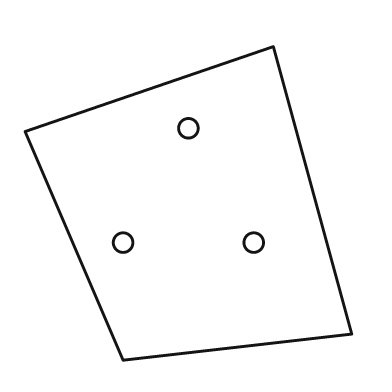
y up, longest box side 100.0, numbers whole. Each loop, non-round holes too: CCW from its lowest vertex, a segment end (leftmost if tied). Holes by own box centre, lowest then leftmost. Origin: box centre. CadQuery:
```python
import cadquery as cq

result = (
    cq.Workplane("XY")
    .moveTo(-20.0, -48.0)
    .lineTo(50.0, -40.0)
    .lineTo(26.0, 48.0)
    .lineTo(-50.0, 22.0)
    .close()
    .moveTo(-20.0, -12.0)
    .circle(3.0)
    .moveTo(20.0, -12.0)
    .circle(3.0)
    .moveTo(0.0, 23.0)
    .circle(3.0)
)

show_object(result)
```